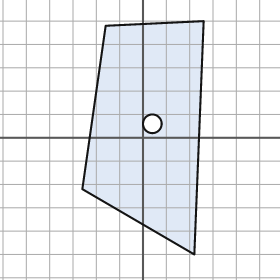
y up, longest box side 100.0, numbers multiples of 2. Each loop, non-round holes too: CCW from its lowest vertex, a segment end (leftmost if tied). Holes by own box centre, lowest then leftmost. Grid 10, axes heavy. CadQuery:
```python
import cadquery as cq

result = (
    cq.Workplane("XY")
    .moveTo(22.0, -50.0)
    .lineTo(26.0, 50.0)
    .lineTo(-16.0, 48.0)
    .lineTo(-26.0, -22.0)
    .close()
    .moveTo(4.0, 6.0)
    .circle(4.0)
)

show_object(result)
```